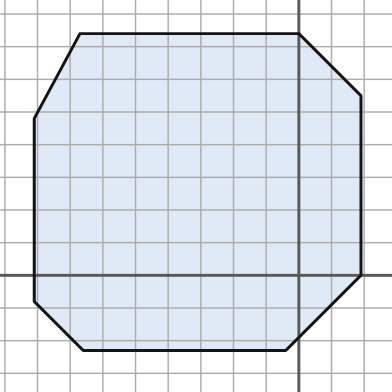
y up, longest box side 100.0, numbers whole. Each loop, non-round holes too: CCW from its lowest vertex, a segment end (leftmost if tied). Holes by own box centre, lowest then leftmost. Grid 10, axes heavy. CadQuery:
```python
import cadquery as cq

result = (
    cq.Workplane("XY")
    .moveTo(-66.0, -23.0)
    .lineTo(-4.0, -23.0)
    .lineTo(19.0, 0.0)
    .lineTo(19.0, 55.0)
    .lineTo(0.0, 74.0)
    .lineTo(-67.0, 74.0)
    .lineTo(-81.0, 48.0)
    .lineTo(-81.0, -8.0)
    .close()
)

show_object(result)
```